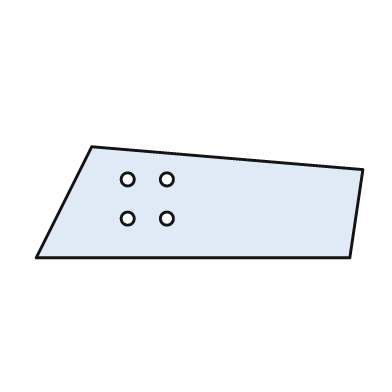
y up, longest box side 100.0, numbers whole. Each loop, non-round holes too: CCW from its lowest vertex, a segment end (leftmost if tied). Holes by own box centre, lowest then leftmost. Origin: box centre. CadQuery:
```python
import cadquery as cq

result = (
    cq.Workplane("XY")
    .moveTo(-50.0, -17.0)
    .lineTo(46.0, -17.0)
    .lineTo(50.0, 10.0)
    .lineTo(-33.0, 17.0)
    .close()
    .moveTo(-22.0, -5.0)
    .circle(2.0)
    .moveTo(-10.0, -5.0)
    .circle(2.0)
    .moveTo(-22.0, 7.0)
    .circle(2.0)
    .moveTo(-10.0, 7.0)
    .circle(2.0)
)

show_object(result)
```